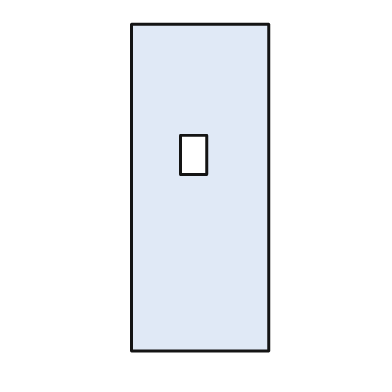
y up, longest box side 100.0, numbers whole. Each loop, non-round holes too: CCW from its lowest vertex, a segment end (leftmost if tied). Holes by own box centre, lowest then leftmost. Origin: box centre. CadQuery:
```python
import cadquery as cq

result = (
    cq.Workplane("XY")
    .moveTo(-21.0, -50.0)
    .lineTo(21.0, -50.0)
    .lineTo(21.0, 50.0)
    .lineTo(-21.0, 50.0)
    .close()
    .moveTo(-6.0, 4.0)
    .lineTo(2.0, 4.0)
    .lineTo(2.0, 16.0)
    .lineTo(-6.0, 16.0)
    .close()
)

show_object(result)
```